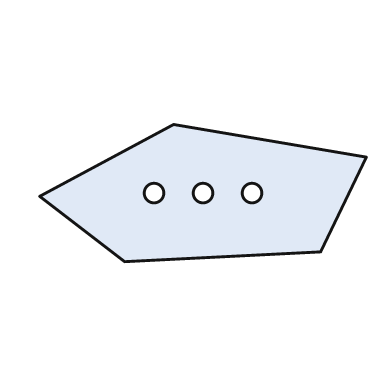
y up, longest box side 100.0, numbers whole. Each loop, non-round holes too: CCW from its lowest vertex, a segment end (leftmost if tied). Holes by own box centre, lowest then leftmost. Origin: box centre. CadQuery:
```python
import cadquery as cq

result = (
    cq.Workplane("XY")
    .moveTo(-24.0, -21.0)
    .lineTo(36.0, -18.0)
    .lineTo(50.0, 11.0)
    .lineTo(-9.0, 21.0)
    .lineTo(-50.0, -1.0)
    .close()
    .moveTo(-15.0, 0.0)
    .circle(3.0)
    .moveTo(0.0, 0.0)
    .circle(3.0)
    .moveTo(15.0, 0.0)
    .circle(3.0)
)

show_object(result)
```